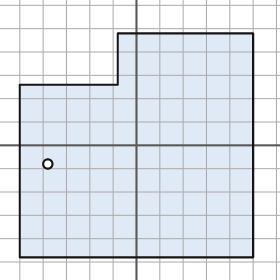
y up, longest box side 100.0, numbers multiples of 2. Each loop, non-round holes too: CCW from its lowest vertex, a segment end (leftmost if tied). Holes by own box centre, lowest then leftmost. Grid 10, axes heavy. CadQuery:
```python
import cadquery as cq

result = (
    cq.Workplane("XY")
    .moveTo(-50.0, -48.0)
    .lineTo(50.0, -48.0)
    .lineTo(50.0, 48.0)
    .lineTo(-8.0, 48.0)
    .lineTo(-8.0, 26.0)
    .lineTo(-50.0, 26.0)
    .close()
    .moveTo(-38.0, -8.0)
    .circle(2.0)
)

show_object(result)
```